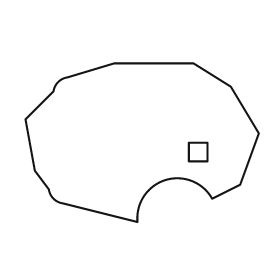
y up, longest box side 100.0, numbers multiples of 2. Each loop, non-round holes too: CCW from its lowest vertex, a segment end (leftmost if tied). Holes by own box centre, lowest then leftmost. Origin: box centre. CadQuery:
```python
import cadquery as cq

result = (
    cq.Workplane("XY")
    .moveTo(-2.0, -34.0)
    .threePointArc((10.0, -16.0), (30.0, -24.0))
    .lineTo(42.0, -18.0)
    .lineTo(50.0, 4.0)
    .lineTo(38.0, 24.0)
    .lineTo(22.0, 34.0)
    .lineTo(-12.0, 34.0)
    .lineTo(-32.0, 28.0)
    .threePointArc((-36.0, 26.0), (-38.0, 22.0))
    .lineTo(-50.0, 10.0)
    .lineTo(-46.0, -12.0)
    .lineTo(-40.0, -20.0)
    .threePointArc((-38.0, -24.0), (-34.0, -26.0))
    .close()
    .moveTo(20.0, -8.0)
    .lineTo(28.0, -8.0)
    .lineTo(28.0, 0.0)
    .lineTo(20.0, 0.0)
    .close()
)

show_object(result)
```